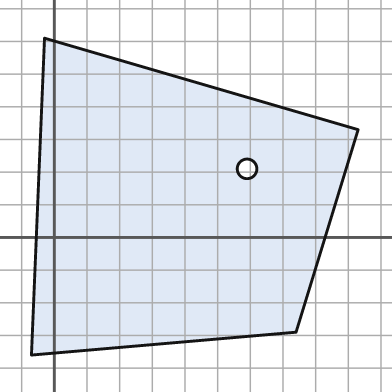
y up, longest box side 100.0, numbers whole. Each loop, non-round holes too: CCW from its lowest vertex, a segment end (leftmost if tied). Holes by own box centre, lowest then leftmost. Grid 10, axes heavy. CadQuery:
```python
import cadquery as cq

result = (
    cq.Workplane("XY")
    .moveTo(-7.0, -36.0)
    .lineTo(74.0, -29.0)
    .lineTo(93.0, 33.0)
    .lineTo(-3.0, 61.0)
    .close()
    .moveTo(59.0, 21.0)
    .circle(3.0)
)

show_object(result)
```